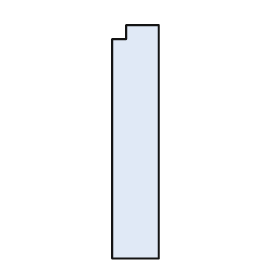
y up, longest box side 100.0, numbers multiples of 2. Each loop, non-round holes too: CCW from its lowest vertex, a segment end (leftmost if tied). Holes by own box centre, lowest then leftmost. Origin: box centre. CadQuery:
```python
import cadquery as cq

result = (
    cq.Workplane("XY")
    .moveTo(-10.0, -50.0)
    .lineTo(10.0, -50.0)
    .lineTo(10.0, 50.0)
    .lineTo(-4.0, 50.0)
    .lineTo(-4.0, 44.0)
    .lineTo(-10.0, 44.0)
    .close()
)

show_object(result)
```